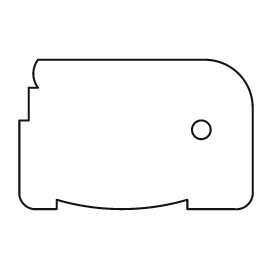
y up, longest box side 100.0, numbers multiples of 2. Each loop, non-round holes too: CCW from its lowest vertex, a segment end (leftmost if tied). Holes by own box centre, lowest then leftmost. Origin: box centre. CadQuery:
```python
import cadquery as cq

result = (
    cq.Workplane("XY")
    .moveTo(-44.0, -32.0)
    .lineTo(-34.0, -32.0)
    .lineTo(-34.0, -28.0)
    .threePointArc((-6.0, -32.0), (22.0, -28.0))
    .lineTo(22.0, -32.0)
    .lineTo(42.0, -32.0)
    .threePointArc((48.0, -30.0), (50.0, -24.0))
    .lineTo(50.0, 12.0)
    .threePointArc((44.0, 26.0), (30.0, 32.0))
    .lineTo(-42.0, 32.0)
    .threePointArc((-44.0, 26.0), (-42.0, 20.0))
    .lineTo(-46.0, 20.0)
    .lineTo(-46.0, 6.0)
    .lineTo(-50.0, 6.0)
    .lineTo(-50.0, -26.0)
    .threePointArc((-48.0, -30.0), (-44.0, -32.0))
    .close()
    .moveTo(28.0, 2.0)
    .circle(4.0)
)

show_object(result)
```